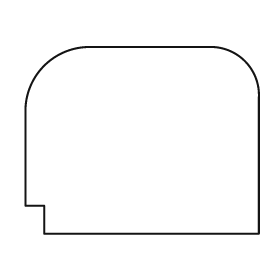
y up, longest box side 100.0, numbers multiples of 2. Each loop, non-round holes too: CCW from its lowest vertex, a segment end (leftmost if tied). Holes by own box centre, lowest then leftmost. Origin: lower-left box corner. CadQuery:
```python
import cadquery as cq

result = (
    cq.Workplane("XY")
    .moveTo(8.0, 0.0)
    .lineTo(100.0, 0.0)
    .lineTo(100.0, 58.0)
    .threePointArc((94.0, 74.0), (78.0, 80.0))
    .lineTo(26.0, 80.0)
    .threePointArc((8.0, 72.0), (0.0, 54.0))
    .lineTo(0.0, 12.0)
    .lineTo(8.0, 12.0)
    .close()
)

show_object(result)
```